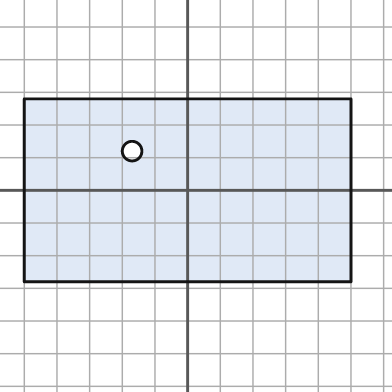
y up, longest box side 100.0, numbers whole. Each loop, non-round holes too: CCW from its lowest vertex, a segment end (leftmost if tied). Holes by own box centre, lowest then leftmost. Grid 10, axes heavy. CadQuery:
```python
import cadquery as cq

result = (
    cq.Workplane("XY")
    .moveTo(-50.0, -28.0)
    .lineTo(50.0, -28.0)
    .lineTo(50.0, 28.0)
    .lineTo(-50.0, 28.0)
    .close()
    .moveTo(-17.0, 12.0)
    .circle(3.0)
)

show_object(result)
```